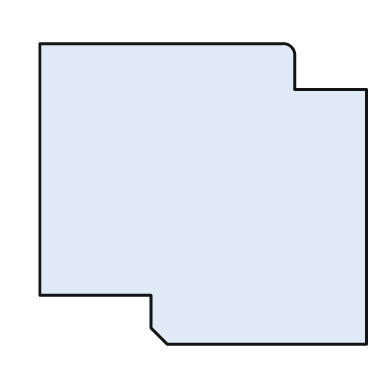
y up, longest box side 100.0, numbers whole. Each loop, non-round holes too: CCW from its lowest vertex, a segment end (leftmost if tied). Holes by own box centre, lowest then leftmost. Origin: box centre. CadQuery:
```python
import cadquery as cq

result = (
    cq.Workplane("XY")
    .moveTo(-11.0, -46.0)
    .lineTo(50.0, -46.0)
    .lineTo(50.0, 32.0)
    .lineTo(28.0, 32.0)
    .lineTo(28.0, 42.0)
    .threePointArc((27.0, 45.0), (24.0, 46.0))
    .lineTo(-50.0, 46.0)
    .lineTo(-50.0, -31.0)
    .lineTo(-16.0, -31.0)
    .lineTo(-16.0, -41.0)
    .close()
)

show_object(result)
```